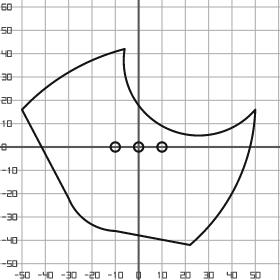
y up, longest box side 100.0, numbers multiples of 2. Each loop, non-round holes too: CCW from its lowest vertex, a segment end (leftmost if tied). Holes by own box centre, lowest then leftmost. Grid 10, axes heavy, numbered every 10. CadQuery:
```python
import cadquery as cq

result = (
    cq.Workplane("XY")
    .moveTo(22.0, -42.0)
    .threePointArc((42.0, -16.0), (50.0, 16.0))
    .threePointArc((12.0, 8.0), (-6.0, 42.0))
    .threePointArc((-30.0, 32.0), (-50.0, 16.0))
    .lineTo(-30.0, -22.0)
    .threePointArc((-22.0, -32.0), (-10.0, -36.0))
    .close()
    .moveTo(-10.0, 0.0)
    .circle(2.0)
    .moveTo(0.0, 0.0)
    .circle(2.0)
    .moveTo(10.0, 0.0)
    .circle(2.0)
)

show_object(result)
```